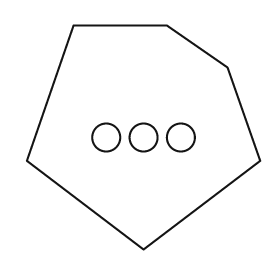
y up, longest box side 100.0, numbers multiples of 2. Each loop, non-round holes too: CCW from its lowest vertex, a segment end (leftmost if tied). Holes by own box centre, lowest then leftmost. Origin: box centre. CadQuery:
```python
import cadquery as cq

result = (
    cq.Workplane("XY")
    .moveTo(0.0, -48.0)
    .lineTo(50.0, -10.0)
    .lineTo(36.0, 30.0)
    .lineTo(10.0, 48.0)
    .lineTo(-30.0, 48.0)
    .lineTo(-50.0, -10.0)
    .close()
    .moveTo(-16.0, 0.0)
    .circle(6.0)
    .moveTo(0.0, 0.0)
    .circle(6.0)
    .moveTo(16.0, 0.0)
    .circle(6.0)
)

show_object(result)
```